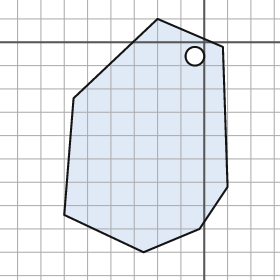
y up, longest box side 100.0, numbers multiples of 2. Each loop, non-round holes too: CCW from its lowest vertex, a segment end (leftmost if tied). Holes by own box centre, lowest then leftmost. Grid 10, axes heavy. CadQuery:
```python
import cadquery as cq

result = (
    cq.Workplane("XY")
    .moveTo(-26.0, -90.0)
    .lineTo(-2.0, -80.0)
    .lineTo(10.0, -62.0)
    .lineTo(8.0, -2.0)
    .lineTo(-20.0, 10.0)
    .lineTo(-56.0, -24.0)
    .lineTo(-60.0, -74.0)
    .close()
    .moveTo(-4.0, -6.0)
    .circle(4.0)
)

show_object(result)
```